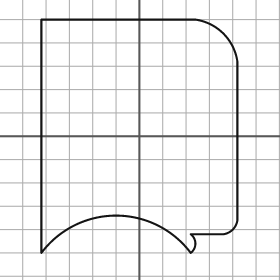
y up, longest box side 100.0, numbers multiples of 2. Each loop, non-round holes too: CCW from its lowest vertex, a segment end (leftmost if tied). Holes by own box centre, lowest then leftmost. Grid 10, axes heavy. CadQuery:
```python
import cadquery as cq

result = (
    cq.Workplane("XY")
    .moveTo(-42.0, -50.0)
    .threePointArc((-10.0, -34.0), (22.0, -50.0))
    .threePointArc((24.0, -46.0), (22.0, -42.0))
    .lineTo(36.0, -42.0)
    .threePointArc((40.0, -40.0), (42.0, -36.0))
    .lineTo(42.0, 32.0)
    .threePointArc((36.0, 44.0), (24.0, 50.0))
    .lineTo(-42.0, 50.0)
    .close()
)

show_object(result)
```